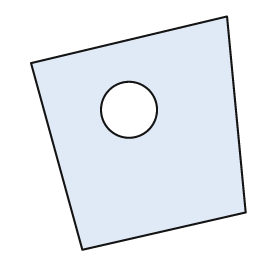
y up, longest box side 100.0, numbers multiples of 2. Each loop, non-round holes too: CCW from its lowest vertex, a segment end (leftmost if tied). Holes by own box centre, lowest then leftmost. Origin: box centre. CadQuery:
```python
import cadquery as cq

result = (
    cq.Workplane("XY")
    .moveTo(-24.0, -50.0)
    .lineTo(46.0, -34.0)
    .lineTo(38.0, 50.0)
    .lineTo(-46.0, 30.0)
    .close()
    .moveTo(-4.0, 10.0)
    .circle(12.0)
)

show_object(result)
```